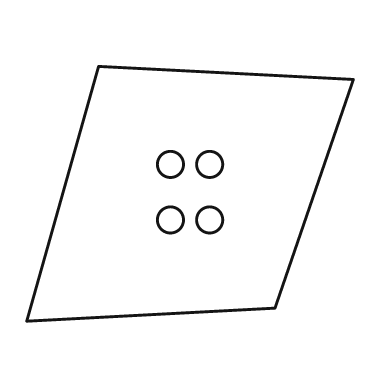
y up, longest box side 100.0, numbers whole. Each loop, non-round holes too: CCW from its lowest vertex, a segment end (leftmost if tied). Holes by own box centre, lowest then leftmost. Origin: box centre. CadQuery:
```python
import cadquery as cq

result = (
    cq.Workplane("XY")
    .moveTo(-50.0, -39.0)
    .lineTo(26.0, -35.0)
    .lineTo(50.0, 35.0)
    .lineTo(-28.0, 39.0)
    .close()
    .moveTo(-6.0, -8.0)
    .circle(4.0)
    .moveTo(6.0, -8.0)
    .circle(4.0)
    .moveTo(-6.0, 9.0)
    .circle(4.0)
    .moveTo(6.0, 9.0)
    .circle(4.0)
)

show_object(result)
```